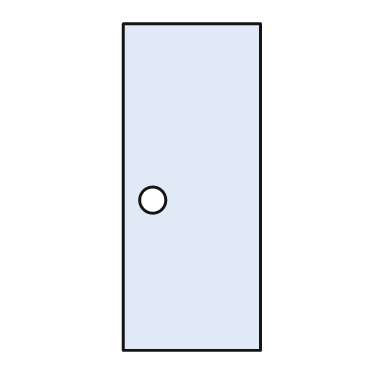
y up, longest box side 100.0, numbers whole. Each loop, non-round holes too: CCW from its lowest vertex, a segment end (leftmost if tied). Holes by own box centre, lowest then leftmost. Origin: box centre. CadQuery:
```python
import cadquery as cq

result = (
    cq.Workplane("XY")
    .moveTo(-21.0, -50.0)
    .lineTo(21.0, -50.0)
    .lineTo(21.0, 50.0)
    .lineTo(-21.0, 50.0)
    .close()
    .moveTo(-12.0, -4.0)
    .circle(4.0)
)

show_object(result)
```